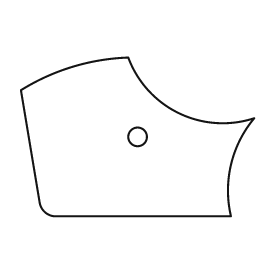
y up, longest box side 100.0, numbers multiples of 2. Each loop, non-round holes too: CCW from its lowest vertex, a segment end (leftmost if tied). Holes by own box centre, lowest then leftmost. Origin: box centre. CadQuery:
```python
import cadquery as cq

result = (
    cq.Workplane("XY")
    .moveTo(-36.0, -34.0)
    .lineTo(40.0, -34.0)
    .threePointArc((40.0, -12.0), (50.0, 8.0))
    .threePointArc((18.0, 10.0), (-4.0, 34.0))
    .threePointArc((-28.0, 30.0), (-50.0, 20.0))
    .lineTo(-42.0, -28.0)
    .threePointArc((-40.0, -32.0), (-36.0, -34.0))
    .close()
    .moveTo(0.0, 0.0)
    .circle(4.0)
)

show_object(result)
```